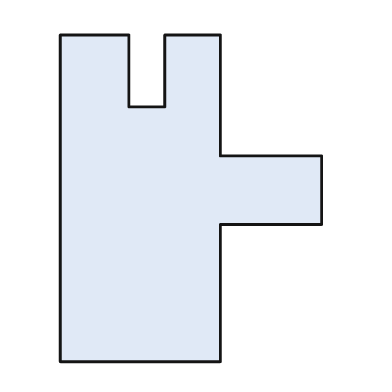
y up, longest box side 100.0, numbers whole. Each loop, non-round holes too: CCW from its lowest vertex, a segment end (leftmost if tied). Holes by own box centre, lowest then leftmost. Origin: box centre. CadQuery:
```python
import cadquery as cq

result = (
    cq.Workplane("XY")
    .moveTo(-40.0, -50.0)
    .lineTo(9.0, -50.0)
    .lineTo(9.0, -8.0)
    .lineTo(40.0, -8.0)
    .lineTo(40.0, 13.0)
    .lineTo(9.0, 13.0)
    .lineTo(9.0, 50.0)
    .lineTo(-8.0, 50.0)
    .lineTo(-8.0, 28.0)
    .lineTo(-19.0, 28.0)
    .lineTo(-19.0, 50.0)
    .lineTo(-40.0, 50.0)
    .close()
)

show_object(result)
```